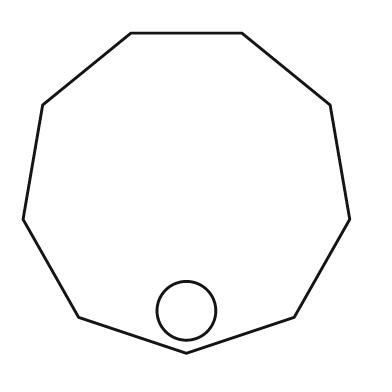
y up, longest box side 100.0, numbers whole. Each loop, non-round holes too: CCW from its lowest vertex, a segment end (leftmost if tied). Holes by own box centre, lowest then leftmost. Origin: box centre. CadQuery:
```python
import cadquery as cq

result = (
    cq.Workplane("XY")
    .moveTo(0.0, -49.0)
    .lineTo(33.0, -38.0)
    .lineTo(50.0, -8.0)
    .lineTo(44.0, 27.0)
    .lineTo(17.0, 49.0)
    .lineTo(-17.0, 49.0)
    .lineTo(-44.0, 27.0)
    .lineTo(-50.0, -8.0)
    .lineTo(-33.0, -38.0)
    .close()
    .moveTo(0.0, -36.0)
    .circle(9.0)
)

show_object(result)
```